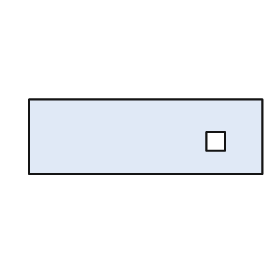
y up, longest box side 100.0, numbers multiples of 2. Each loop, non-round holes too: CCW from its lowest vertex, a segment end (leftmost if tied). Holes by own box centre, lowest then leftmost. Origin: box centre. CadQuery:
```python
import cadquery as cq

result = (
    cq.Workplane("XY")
    .moveTo(-50.0, -16.0)
    .lineTo(50.0, -16.0)
    .lineTo(50.0, 16.0)
    .lineTo(-50.0, 16.0)
    .close()
    .moveTo(26.0, -6.0)
    .lineTo(34.0, -6.0)
    .lineTo(34.0, 2.0)
    .lineTo(26.0, 2.0)
    .close()
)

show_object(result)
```